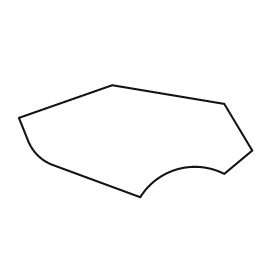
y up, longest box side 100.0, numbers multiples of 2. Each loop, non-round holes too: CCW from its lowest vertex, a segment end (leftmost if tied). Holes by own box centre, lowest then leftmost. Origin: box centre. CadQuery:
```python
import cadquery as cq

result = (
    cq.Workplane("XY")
    .moveTo(2.0, -24.0)
    .threePointArc((18.0, -12.0), (38.0, -14.0))
    .lineTo(50.0, -4.0)
    .lineTo(38.0, 16.0)
    .lineTo(-10.0, 24.0)
    .lineTo(-50.0, 10.0)
    .lineTo(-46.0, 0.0)
    .threePointArc((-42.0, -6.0), (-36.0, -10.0))
    .close()
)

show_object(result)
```